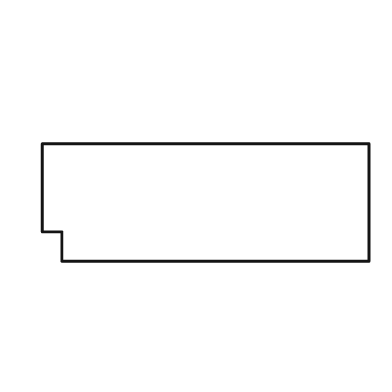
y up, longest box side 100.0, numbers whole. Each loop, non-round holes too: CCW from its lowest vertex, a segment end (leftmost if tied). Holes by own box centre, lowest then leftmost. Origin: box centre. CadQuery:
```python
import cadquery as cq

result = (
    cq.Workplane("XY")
    .moveTo(-44.0, -18.0)
    .lineTo(50.0, -18.0)
    .lineTo(50.0, 18.0)
    .lineTo(-50.0, 18.0)
    .lineTo(-50.0, -9.0)
    .lineTo(-44.0, -9.0)
    .close()
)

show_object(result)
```